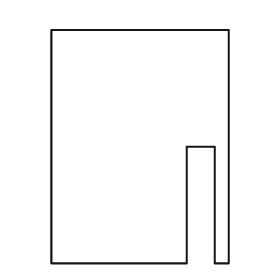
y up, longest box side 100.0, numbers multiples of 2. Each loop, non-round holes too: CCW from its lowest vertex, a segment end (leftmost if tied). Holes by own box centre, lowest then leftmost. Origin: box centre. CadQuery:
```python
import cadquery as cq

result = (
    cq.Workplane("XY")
    .moveTo(-38.0, -50.0)
    .lineTo(20.0, -50.0)
    .lineTo(20.0, 0.0)
    .lineTo(32.0, 0.0)
    .lineTo(32.0, -50.0)
    .lineTo(38.0, -50.0)
    .lineTo(38.0, 50.0)
    .lineTo(-38.0, 50.0)
    .close()
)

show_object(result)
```